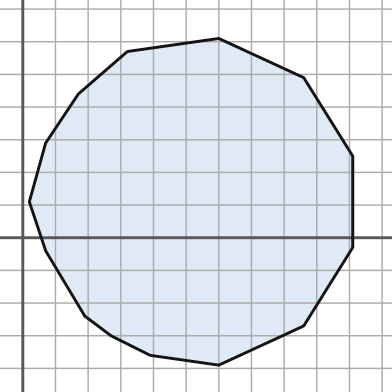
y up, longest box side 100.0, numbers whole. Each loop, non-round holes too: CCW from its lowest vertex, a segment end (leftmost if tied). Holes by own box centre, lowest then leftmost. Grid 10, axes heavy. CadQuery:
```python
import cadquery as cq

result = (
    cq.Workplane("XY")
    .moveTo(60.0, -39.0)
    .lineTo(86.0, -27.0)
    .lineTo(101.0, -3.0)
    .lineTo(101.0, 25.0)
    .lineTo(86.0, 49.0)
    .lineTo(60.0, 61.0)
    .lineTo(32.0, 57.0)
    .lineTo(17.0, 44.0)
    .lineTo(7.0, 29.0)
    .lineTo(2.0, 11.0)
    .lineTo(7.0, -4.0)
    .lineTo(19.0, -24.0)
    .lineTo(27.0, -30.0)
    .lineTo(39.0, -36.0)
    .close()
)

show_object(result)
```